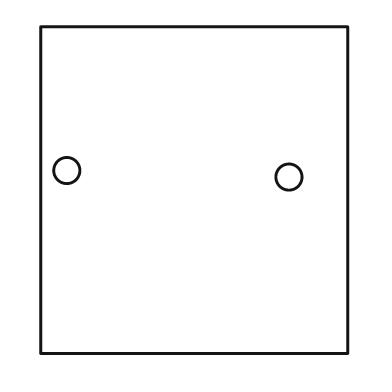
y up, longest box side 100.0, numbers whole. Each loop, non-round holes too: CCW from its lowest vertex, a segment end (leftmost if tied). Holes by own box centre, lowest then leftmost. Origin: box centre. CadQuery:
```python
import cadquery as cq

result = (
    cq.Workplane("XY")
    .moveTo(-47.0, -50.0)
    .lineTo(47.0, -50.0)
    .lineTo(47.0, 50.0)
    .lineTo(-47.0, 50.0)
    .close()
    .moveTo(29.0, 4.0)
    .circle(4.0)
    .moveTo(-39.0, 6.0)
    .circle(4.0)
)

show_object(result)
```